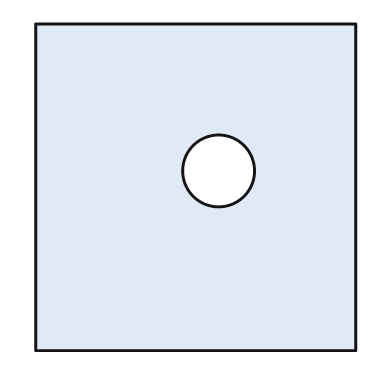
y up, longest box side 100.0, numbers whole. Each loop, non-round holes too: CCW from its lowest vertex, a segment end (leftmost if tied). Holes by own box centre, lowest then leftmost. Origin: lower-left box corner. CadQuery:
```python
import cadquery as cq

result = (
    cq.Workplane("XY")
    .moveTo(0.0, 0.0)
    .lineTo(98.0, 0.0)
    .lineTo(98.0, 100.0)
    .lineTo(0.0, 100.0)
    .close()
    .moveTo(56.0, 55.0)
    .circle(11.0)
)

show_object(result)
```